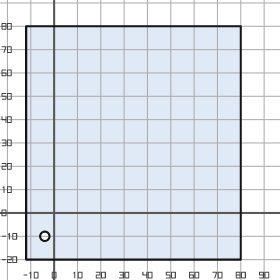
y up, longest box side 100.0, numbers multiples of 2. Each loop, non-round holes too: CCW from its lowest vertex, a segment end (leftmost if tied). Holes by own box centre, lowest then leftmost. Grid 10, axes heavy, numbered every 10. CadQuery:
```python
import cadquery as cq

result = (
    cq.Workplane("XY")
    .moveTo(-12.0, -20.0)
    .lineTo(80.0, -20.0)
    .lineTo(80.0, 80.0)
    .lineTo(-12.0, 80.0)
    .close()
    .moveTo(-4.0, -10.0)
    .circle(2.0)
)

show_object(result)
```